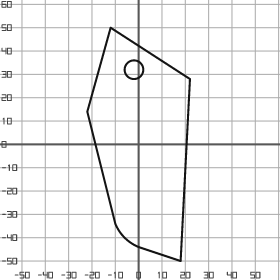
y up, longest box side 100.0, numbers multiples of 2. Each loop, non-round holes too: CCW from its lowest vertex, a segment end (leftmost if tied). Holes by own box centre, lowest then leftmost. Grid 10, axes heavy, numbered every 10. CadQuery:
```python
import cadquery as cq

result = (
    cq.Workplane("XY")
    .moveTo(18.0, -50.0)
    .lineTo(22.0, 28.0)
    .lineTo(-12.0, 50.0)
    .lineTo(-22.0, 14.0)
    .lineTo(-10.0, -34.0)
    .threePointArc((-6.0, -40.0), (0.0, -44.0))
    .close()
    .moveTo(-2.0, 32.0)
    .circle(4.0)
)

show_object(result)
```